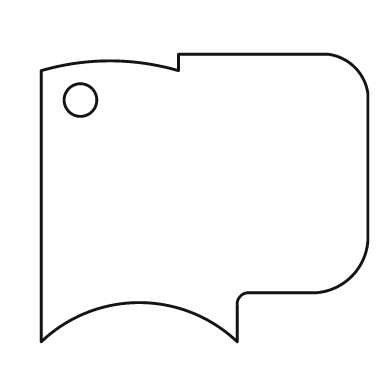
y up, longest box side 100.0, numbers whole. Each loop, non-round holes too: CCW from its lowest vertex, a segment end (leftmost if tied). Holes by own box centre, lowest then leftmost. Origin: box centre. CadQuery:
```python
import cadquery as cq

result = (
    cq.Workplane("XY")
    .moveTo(-50.0, -44.0)
    .threePointArc((-20.0, -32.0), (10.0, -44.0))
    .lineTo(10.0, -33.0)
    .threePointArc((11.0, -30.0), (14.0, -29.0))
    .lineTo(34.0, -29.0)
    .threePointArc((45.0, -24.0), (50.0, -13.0))
    .lineTo(50.0, 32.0)
    .threePointArc((46.0, 40.0), (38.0, 44.0))
    .lineTo(-8.0, 44.0)
    .lineTo(-8.0, 39.0)
    .threePointArc((-29.0, 42.0), (-50.0, 39.0))
    .close()
    .moveTo(-38.0, 30.0)
    .circle(5.0)
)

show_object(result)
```